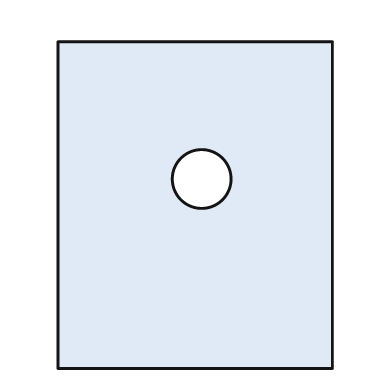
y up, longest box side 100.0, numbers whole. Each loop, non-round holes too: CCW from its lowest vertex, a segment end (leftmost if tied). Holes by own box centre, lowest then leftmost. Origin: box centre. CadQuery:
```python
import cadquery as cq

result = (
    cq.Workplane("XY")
    .moveTo(-42.0, -50.0)
    .lineTo(42.0, -50.0)
    .lineTo(42.0, 50.0)
    .lineTo(-42.0, 50.0)
    .close()
    .moveTo(2.0, 8.0)
    .circle(9.0)
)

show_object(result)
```